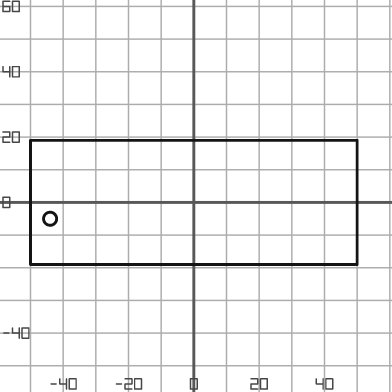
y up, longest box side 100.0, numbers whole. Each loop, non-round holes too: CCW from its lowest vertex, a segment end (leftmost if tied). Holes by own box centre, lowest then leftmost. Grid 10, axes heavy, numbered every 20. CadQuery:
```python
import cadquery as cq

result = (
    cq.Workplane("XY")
    .moveTo(-50.0, -19.0)
    .lineTo(50.0, -19.0)
    .lineTo(50.0, 19.0)
    .lineTo(-50.0, 19.0)
    .close()
    .moveTo(-44.0, -5.0)
    .circle(2.0)
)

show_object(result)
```